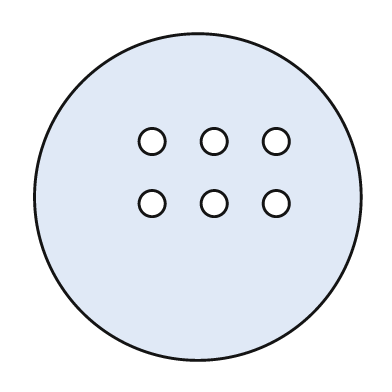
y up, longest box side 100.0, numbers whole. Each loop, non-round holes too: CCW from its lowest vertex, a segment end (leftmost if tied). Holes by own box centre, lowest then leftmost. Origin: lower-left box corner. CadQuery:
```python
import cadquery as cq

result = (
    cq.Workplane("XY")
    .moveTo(50.0, 50.0)
    .circle(50.0)
    .moveTo(36.0, 48.0)
    .circle(4.0)
    .moveTo(55.0, 48.0)
    .circle(4.0)
    .moveTo(74.0, 48.0)
    .circle(4.0)
    .moveTo(36.0, 67.0)
    .circle(4.0)
    .moveTo(55.0, 67.0)
    .circle(4.0)
    .moveTo(74.0, 67.0)
    .circle(4.0)
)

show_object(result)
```